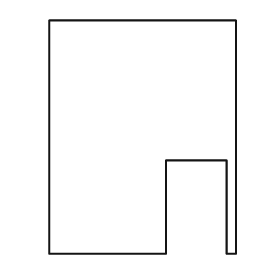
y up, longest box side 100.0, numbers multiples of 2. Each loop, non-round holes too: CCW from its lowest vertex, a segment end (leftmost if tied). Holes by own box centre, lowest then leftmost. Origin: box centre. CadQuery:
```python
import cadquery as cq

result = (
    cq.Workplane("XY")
    .moveTo(-40.0, -50.0)
    .lineTo(10.0, -50.0)
    .lineTo(10.0, -10.0)
    .lineTo(36.0, -10.0)
    .lineTo(36.0, -50.0)
    .lineTo(40.0, -50.0)
    .lineTo(40.0, 50.0)
    .lineTo(-40.0, 50.0)
    .close()
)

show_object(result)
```